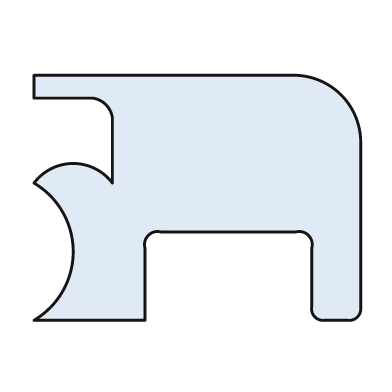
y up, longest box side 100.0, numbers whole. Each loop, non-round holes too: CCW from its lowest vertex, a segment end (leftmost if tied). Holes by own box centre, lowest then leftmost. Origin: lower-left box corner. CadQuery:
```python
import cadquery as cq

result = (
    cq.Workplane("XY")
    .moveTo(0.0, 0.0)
    .lineTo(34.0, 0.0)
    .lineTo(34.0, 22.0)
    .threePointArc((35.0, 26.0), (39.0, 27.0))
    .lineTo(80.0, 27.0)
    .threePointArc((84.0, 26.0), (85.0, 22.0))
    .lineTo(85.0, 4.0)
    .threePointArc((86.0, 1.0), (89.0, 0.0))
    .lineTo(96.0, 0.0)
    .threePointArc((99.0, 1.0), (100.0, 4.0))
    .lineTo(100.0, 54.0)
    .threePointArc((94.0, 69.0), (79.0, 75.0))
    .lineTo(0.0, 75.0)
    .lineTo(0.0, 68.0)
    .lineTo(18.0, 68.0)
    .threePointArc((22.0, 66.0), (24.0, 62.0))
    .lineTo(24.0, 42.0)
    .threePointArc((12.0, 48.0), (0.0, 42.0))
    .threePointArc((12.0, 21.0), (0.0, 0.0))
    .close()
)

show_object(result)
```